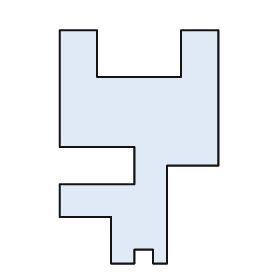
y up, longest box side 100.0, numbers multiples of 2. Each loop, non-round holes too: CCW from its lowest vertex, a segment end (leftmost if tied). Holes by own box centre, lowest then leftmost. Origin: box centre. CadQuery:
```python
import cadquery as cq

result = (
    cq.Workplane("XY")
    .moveTo(-12.0, -50.0)
    .lineTo(-2.0, -50.0)
    .lineTo(-2.0, -44.0)
    .lineTo(6.0, -44.0)
    .lineTo(6.0, -50.0)
    .lineTo(12.0, -50.0)
    .lineTo(12.0, -8.0)
    .lineTo(34.0, -8.0)
    .lineTo(34.0, 50.0)
    .lineTo(18.0, 50.0)
    .lineTo(18.0, 30.0)
    .lineTo(-18.0, 30.0)
    .lineTo(-18.0, 50.0)
    .lineTo(-34.0, 50.0)
    .lineTo(-34.0, 0.0)
    .lineTo(-2.0, 0.0)
    .lineTo(-2.0, -16.0)
    .lineTo(-34.0, -16.0)
    .lineTo(-34.0, -30.0)
    .lineTo(-12.0, -30.0)
    .close()
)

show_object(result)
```